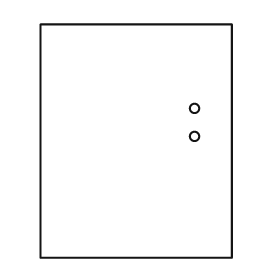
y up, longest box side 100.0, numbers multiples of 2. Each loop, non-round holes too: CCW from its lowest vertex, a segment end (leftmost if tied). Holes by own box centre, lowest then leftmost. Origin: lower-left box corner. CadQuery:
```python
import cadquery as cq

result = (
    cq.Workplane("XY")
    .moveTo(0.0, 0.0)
    .lineTo(82.0, 0.0)
    .lineTo(82.0, 100.0)
    .lineTo(0.0, 100.0)
    .close()
    .moveTo(66.0, 52.0)
    .circle(2.0)
    .moveTo(66.0, 64.0)
    .circle(2.0)
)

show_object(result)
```